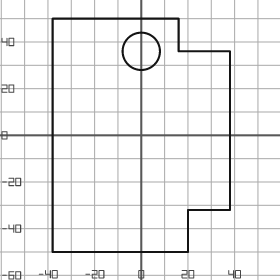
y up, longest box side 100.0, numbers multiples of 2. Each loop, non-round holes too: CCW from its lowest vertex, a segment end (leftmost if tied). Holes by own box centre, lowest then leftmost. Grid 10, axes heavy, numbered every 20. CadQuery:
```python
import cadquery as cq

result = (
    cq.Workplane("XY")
    .moveTo(-38.0, -50.0)
    .lineTo(20.0, -50.0)
    .lineTo(20.0, -32.0)
    .lineTo(38.0, -32.0)
    .lineTo(38.0, 36.0)
    .lineTo(16.0, 36.0)
    .lineTo(16.0, 50.0)
    .lineTo(-38.0, 50.0)
    .close()
    .moveTo(0.0, 36.0)
    .circle(8.0)
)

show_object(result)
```